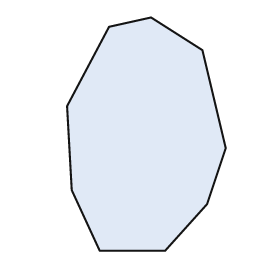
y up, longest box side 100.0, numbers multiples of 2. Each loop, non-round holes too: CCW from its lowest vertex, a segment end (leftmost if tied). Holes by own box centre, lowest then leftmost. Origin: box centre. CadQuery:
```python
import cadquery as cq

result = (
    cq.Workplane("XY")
    .moveTo(-20.0, -50.0)
    .lineTo(8.0, -50.0)
    .lineTo(26.0, -30.0)
    .lineTo(34.0, -6.0)
    .lineTo(24.0, 36.0)
    .lineTo(2.0, 50.0)
    .lineTo(-16.0, 46.0)
    .lineTo(-34.0, 12.0)
    .lineTo(-32.0, -24.0)
    .close()
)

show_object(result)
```